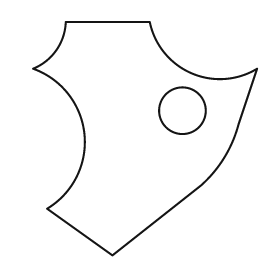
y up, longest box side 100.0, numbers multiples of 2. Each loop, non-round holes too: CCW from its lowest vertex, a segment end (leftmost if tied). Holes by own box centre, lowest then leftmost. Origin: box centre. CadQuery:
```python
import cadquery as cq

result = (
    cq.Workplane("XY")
    .moveTo(-14.0, -50.0)
    .lineTo(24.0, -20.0)
    .threePointArc((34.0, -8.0), (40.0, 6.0))
    .lineTo(48.0, 30.0)
    .threePointArc((20.0, 28.0), (2.0, 50.0))
    .lineTo(-34.0, 50.0)
    .threePointArc((-38.0, 38.0), (-48.0, 30.0))
    .threePointArc((-26.0, 2.0), (-42.0, -30.0))
    .close()
    .moveTo(16.0, 12.0)
    .circle(10.0)
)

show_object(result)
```